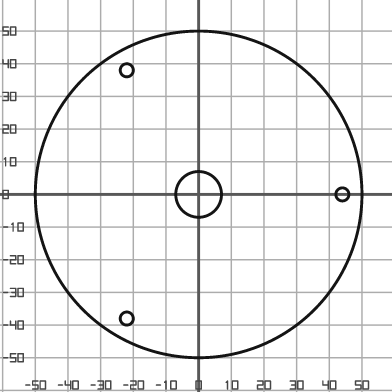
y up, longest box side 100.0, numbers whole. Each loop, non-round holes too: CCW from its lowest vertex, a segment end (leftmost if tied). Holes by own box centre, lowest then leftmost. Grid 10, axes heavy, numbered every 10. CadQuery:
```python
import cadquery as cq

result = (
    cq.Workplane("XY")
    .moveTo(0.0, 0.0)
    .circle(50.0)
    .moveTo(-22.0, -38.0)
    .circle(2.0)
    .moveTo(0.0, 0.0)
    .circle(7.0)
    .moveTo(44.0, 0.0)
    .circle(2.0)
    .moveTo(-22.0, 38.0)
    .circle(2.0)
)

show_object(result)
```